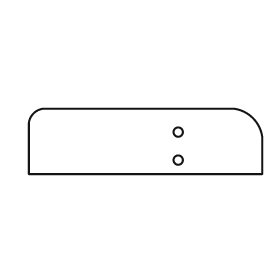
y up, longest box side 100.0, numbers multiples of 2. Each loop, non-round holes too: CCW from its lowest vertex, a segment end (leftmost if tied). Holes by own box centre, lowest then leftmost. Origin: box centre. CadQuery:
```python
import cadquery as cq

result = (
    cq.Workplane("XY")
    .moveTo(-50.0, -14.0)
    .lineTo(50.0, -14.0)
    .lineTo(50.0, 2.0)
    .threePointArc((46.0, 10.0), (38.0, 14.0))
    .lineTo(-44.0, 14.0)
    .threePointArc((-48.0, 12.0), (-50.0, 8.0))
    .close()
    .moveTo(14.0, -8.0)
    .circle(2.0)
    .moveTo(14.0, 4.0)
    .circle(2.0)
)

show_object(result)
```